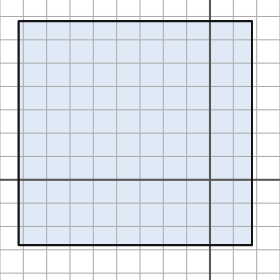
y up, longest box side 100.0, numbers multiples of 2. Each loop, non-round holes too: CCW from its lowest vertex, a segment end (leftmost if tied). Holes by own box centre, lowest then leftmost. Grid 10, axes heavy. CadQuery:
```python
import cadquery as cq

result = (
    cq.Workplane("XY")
    .moveTo(-82.0, -28.0)
    .lineTo(18.0, -28.0)
    .lineTo(18.0, 68.0)
    .lineTo(-82.0, 68.0)
    .close()
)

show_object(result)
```